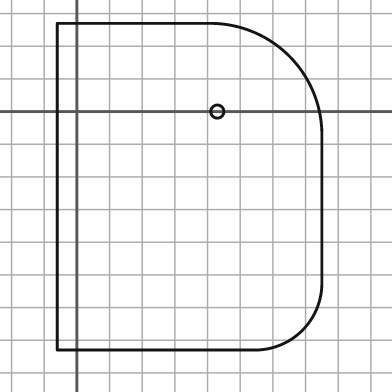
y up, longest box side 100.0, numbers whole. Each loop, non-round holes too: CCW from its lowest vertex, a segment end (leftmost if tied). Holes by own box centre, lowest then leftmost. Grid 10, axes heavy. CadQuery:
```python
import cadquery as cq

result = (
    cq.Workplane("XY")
    .moveTo(-6.0, -73.0)
    .lineTo(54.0, -73.0)
    .threePointArc((69.0, -67.0), (75.0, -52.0))
    .lineTo(75.0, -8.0)
    .threePointArc((65.0, 17.0), (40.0, 27.0))
    .lineTo(-6.0, 27.0)
    .close()
    .moveTo(43.0, 0.0)
    .circle(2.0)
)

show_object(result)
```